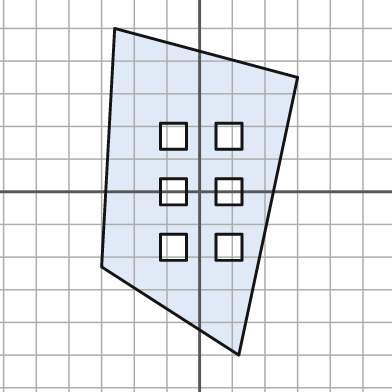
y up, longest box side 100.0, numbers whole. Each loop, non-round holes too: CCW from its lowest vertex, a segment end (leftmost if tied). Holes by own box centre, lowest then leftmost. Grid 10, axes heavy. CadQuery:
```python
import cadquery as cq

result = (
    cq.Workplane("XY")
    .moveTo(12.0, -50.0)
    .lineTo(30.0, 35.0)
    .lineTo(-26.0, 50.0)
    .lineTo(-30.0, -23.0)
    .close()
    .moveTo(-12.0, -21.0)
    .lineTo(-4.0, -21.0)
    .lineTo(-4.0, -13.0)
    .lineTo(-12.0, -13.0)
    .close()
    .moveTo(5.0, -21.0)
    .lineTo(13.0, -21.0)
    .lineTo(13.0, -13.0)
    .lineTo(5.0, -13.0)
    .close()
    .moveTo(-12.0, -4.0)
    .lineTo(-4.0, -4.0)
    .lineTo(-4.0, 4.0)
    .lineTo(-12.0, 4.0)
    .close()
    .moveTo(5.0, -4.0)
    .lineTo(13.0, -4.0)
    .lineTo(13.0, 4.0)
    .lineTo(5.0, 4.0)
    .close()
    .moveTo(-12.0, 13.0)
    .lineTo(-4.0, 13.0)
    .lineTo(-4.0, 21.0)
    .lineTo(-12.0, 21.0)
    .close()
    .moveTo(5.0, 13.0)
    .lineTo(13.0, 13.0)
    .lineTo(13.0, 21.0)
    .lineTo(5.0, 21.0)
    .close()
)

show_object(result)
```